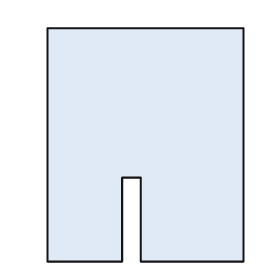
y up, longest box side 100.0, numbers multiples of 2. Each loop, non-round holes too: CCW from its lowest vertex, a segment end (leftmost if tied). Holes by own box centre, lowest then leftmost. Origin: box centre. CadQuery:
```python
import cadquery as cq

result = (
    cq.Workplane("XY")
    .moveTo(-42.0, -50.0)
    .lineTo(-10.0, -50.0)
    .lineTo(-10.0, -14.0)
    .lineTo(-2.0, -14.0)
    .lineTo(-2.0, -50.0)
    .lineTo(42.0, -50.0)
    .lineTo(42.0, 50.0)
    .lineTo(-42.0, 50.0)
    .close()
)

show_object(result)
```